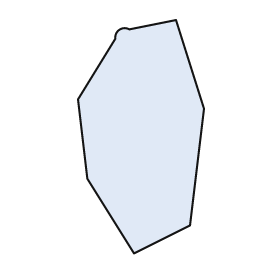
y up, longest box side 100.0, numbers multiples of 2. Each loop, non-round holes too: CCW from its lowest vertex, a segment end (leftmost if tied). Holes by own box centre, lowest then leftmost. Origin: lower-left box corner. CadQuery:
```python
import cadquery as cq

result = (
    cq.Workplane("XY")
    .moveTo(24.0, 0.0)
    .lineTo(48.0, 12.0)
    .lineTo(54.0, 62.0)
    .lineTo(42.0, 100.0)
    .lineTo(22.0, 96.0)
    .threePointArc((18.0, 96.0), (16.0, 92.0))
    .lineTo(0.0, 66.0)
    .lineTo(4.0, 32.0)
    .close()
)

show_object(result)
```